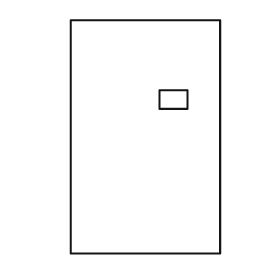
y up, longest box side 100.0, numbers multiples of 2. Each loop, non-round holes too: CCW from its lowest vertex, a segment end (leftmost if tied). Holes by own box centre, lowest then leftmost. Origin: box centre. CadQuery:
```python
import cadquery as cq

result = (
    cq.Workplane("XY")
    .moveTo(-32.0, -50.0)
    .lineTo(32.0, -50.0)
    .lineTo(32.0, 50.0)
    .lineTo(-32.0, 50.0)
    .close()
    .moveTo(6.0, 12.0)
    .lineTo(18.0, 12.0)
    .lineTo(18.0, 20.0)
    .lineTo(6.0, 20.0)
    .close()
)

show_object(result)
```